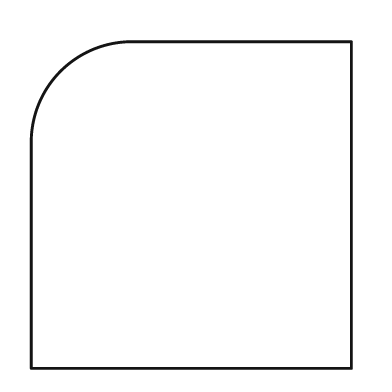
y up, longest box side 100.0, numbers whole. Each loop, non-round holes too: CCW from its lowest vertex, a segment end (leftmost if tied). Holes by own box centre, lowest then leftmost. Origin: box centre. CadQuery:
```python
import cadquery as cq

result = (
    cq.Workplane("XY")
    .moveTo(-49.0, -50.0)
    .lineTo(49.0, -50.0)
    .lineTo(49.0, 50.0)
    .lineTo(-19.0, 50.0)
    .threePointArc((-40.0, 41.0), (-49.0, 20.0))
    .close()
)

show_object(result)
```